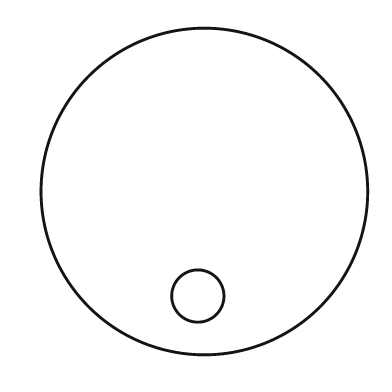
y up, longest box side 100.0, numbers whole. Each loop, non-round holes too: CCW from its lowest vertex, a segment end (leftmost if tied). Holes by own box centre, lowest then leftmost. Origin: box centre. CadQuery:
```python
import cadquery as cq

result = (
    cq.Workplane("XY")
    .moveTo(0.0, 0.0)
    .circle(50.0)
    .moveTo(-2.0, -32.0)
    .circle(8.0)
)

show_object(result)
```